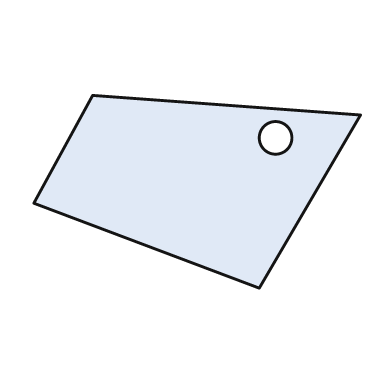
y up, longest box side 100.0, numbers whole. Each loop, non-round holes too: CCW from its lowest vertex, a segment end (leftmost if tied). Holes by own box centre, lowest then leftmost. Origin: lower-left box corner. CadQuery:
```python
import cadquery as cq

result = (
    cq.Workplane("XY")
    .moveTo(69.0, 0.0)
    .lineTo(100.0, 53.0)
    .lineTo(18.0, 59.0)
    .lineTo(0.0, 26.0)
    .close()
    .moveTo(74.0, 46.0)
    .circle(5.0)
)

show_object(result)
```